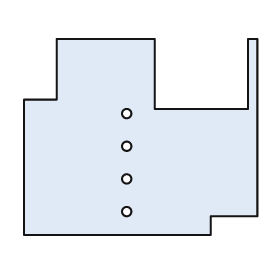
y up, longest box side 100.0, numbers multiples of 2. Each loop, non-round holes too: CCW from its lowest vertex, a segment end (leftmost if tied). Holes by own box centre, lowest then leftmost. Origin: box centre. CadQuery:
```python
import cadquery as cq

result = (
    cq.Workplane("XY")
    .moveTo(-50.0, -42.0)
    .lineTo(30.0, -42.0)
    .lineTo(30.0, -34.0)
    .lineTo(50.0, -34.0)
    .lineTo(50.0, 42.0)
    .lineTo(46.0, 42.0)
    .lineTo(46.0, 12.0)
    .lineTo(6.0, 12.0)
    .lineTo(6.0, 42.0)
    .lineTo(-36.0, 42.0)
    .lineTo(-36.0, 16.0)
    .lineTo(-50.0, 16.0)
    .close()
    .moveTo(-6.0, -32.0)
    .circle(2.0)
    .moveTo(-6.0, -18.0)
    .circle(2.0)
    .moveTo(-6.0, -4.0)
    .circle(2.0)
    .moveTo(-6.0, 10.0)
    .circle(2.0)
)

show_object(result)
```